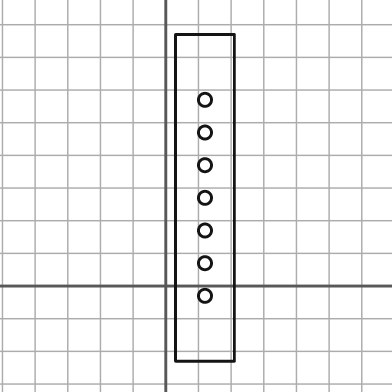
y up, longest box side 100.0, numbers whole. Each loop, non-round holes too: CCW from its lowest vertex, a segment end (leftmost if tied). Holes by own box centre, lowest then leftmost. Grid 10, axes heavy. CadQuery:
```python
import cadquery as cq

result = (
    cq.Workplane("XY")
    .moveTo(3.0, -23.0)
    .lineTo(21.0, -23.0)
    .lineTo(21.0, 77.0)
    .lineTo(3.0, 77.0)
    .close()
    .moveTo(12.0, -3.0)
    .circle(2.0)
    .moveTo(12.0, 7.0)
    .circle(2.0)
    .moveTo(12.0, 17.0)
    .circle(2.0)
    .moveTo(12.0, 27.0)
    .circle(2.0)
    .moveTo(12.0, 37.0)
    .circle(2.0)
    .moveTo(12.0, 47.0)
    .circle(2.0)
    .moveTo(12.0, 57.0)
    .circle(2.0)
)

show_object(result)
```